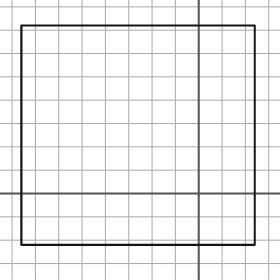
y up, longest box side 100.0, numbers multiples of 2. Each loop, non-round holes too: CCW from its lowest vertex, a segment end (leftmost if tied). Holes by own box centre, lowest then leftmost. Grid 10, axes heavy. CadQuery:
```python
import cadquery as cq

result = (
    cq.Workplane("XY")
    .moveTo(-76.0, -22.0)
    .lineTo(24.0, -22.0)
    .lineTo(24.0, 72.0)
    .lineTo(-76.0, 72.0)
    .close()
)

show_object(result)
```